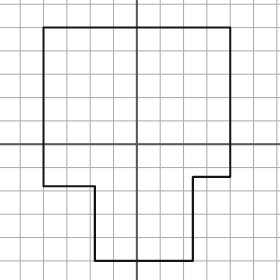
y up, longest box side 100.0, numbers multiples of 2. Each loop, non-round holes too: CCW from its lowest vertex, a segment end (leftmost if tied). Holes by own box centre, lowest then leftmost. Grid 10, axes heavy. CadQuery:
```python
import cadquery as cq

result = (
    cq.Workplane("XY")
    .moveTo(-18.0, -50.0)
    .lineTo(24.0, -50.0)
    .lineTo(24.0, -14.0)
    .lineTo(40.0, -14.0)
    .lineTo(40.0, 50.0)
    .lineTo(-40.0, 50.0)
    .lineTo(-40.0, -18.0)
    .lineTo(-18.0, -18.0)
    .close()
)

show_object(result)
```